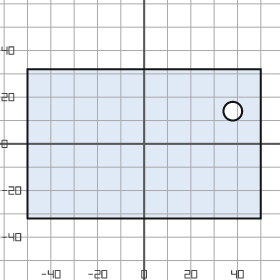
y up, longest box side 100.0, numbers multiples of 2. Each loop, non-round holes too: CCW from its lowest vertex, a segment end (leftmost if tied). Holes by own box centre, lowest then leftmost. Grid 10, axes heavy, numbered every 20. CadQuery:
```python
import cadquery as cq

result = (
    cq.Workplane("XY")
    .moveTo(-50.0, -32.0)
    .lineTo(50.0, -32.0)
    .lineTo(50.0, 32.0)
    .lineTo(-50.0, 32.0)
    .close()
    .moveTo(38.0, 14.0)
    .circle(4.0)
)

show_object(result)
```